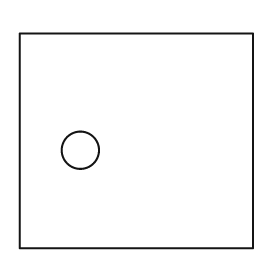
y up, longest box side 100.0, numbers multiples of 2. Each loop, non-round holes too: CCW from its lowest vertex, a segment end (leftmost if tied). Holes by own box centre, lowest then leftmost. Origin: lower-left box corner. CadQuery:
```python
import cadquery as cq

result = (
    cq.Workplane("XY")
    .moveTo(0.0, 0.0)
    .lineTo(100.0, 0.0)
    .lineTo(100.0, 92.0)
    .lineTo(0.0, 92.0)
    .close()
    .moveTo(26.0, 42.0)
    .circle(8.0)
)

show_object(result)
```